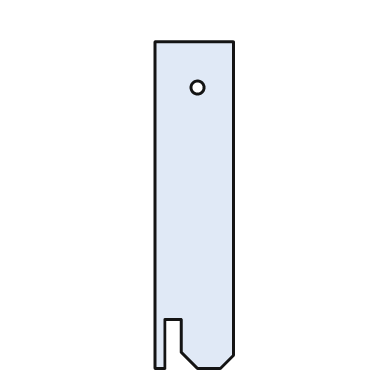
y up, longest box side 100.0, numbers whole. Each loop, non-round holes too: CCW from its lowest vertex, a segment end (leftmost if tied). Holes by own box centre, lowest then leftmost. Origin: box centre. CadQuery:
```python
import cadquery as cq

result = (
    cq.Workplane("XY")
    .moveTo(-12.0, -50.0)
    .lineTo(-9.0, -50.0)
    .lineTo(-9.0, -35.0)
    .lineTo(-4.0, -35.0)
    .lineTo(-4.0, -45.0)
    .lineTo(1.0, -50.0)
    .lineTo(8.0, -50.0)
    .lineTo(12.0, -46.0)
    .lineTo(12.0, 50.0)
    .lineTo(-12.0, 50.0)
    .close()
    .moveTo(1.0, 36.0)
    .circle(2.0)
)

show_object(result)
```